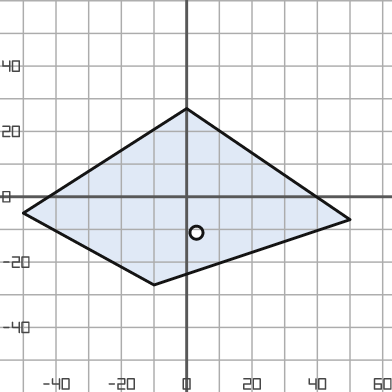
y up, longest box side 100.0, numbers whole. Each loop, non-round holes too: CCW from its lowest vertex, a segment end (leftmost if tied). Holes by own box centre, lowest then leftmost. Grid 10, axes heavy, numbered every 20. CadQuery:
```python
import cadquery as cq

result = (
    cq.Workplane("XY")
    .moveTo(-10.0, -27.0)
    .lineTo(50.0, -7.0)
    .lineTo(0.0, 27.0)
    .lineTo(-50.0, -5.0)
    .close()
    .moveTo(3.0, -11.0)
    .circle(2.0)
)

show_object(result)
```